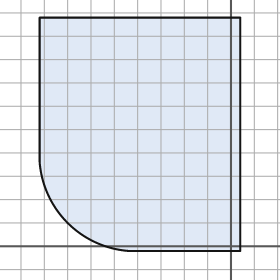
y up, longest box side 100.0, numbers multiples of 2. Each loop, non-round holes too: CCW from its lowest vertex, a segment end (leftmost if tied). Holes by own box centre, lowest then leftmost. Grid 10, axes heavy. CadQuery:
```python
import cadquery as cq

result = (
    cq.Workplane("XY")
    .moveTo(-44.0, -2.0)
    .lineTo(4.0, -2.0)
    .lineTo(4.0, 98.0)
    .lineTo(-82.0, 98.0)
    .lineTo(-82.0, 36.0)
    .threePointArc((-70.0, 10.0), (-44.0, -2.0))
    .close()
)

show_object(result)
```